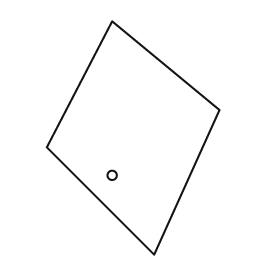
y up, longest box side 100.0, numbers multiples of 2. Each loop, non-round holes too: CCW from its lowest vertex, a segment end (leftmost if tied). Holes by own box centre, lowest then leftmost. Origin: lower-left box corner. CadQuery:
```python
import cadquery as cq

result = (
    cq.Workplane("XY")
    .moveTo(46.0, 0.0)
    .lineTo(74.0, 62.0)
    .lineTo(28.0, 100.0)
    .lineTo(0.0, 46.0)
    .close()
    .moveTo(28.0, 34.0)
    .circle(2.0)
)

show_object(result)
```